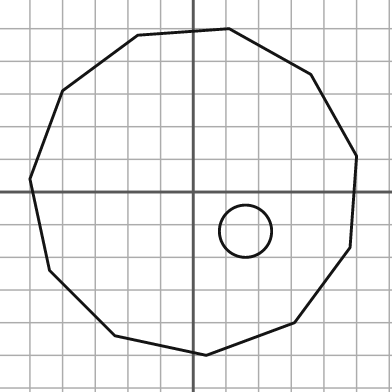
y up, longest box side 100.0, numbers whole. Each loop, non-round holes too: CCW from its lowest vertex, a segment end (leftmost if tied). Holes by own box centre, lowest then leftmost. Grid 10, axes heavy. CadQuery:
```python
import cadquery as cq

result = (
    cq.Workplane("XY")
    .moveTo(4.0, -50.0)
    .lineTo(31.0, -40.0)
    .lineTo(48.0, -17.0)
    .lineTo(50.0, 11.0)
    .lineTo(36.0, 36.0)
    .lineTo(11.0, 50.0)
    .lineTo(-17.0, 48.0)
    .lineTo(-40.0, 31.0)
    .lineTo(-50.0, 4.0)
    .lineTo(-44.0, -24.0)
    .lineTo(-24.0, -44.0)
    .close()
    .moveTo(16.0, -12.0)
    .circle(8.0)
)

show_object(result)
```